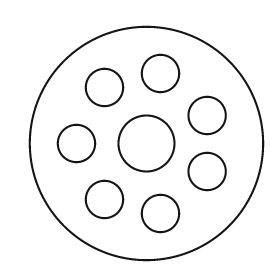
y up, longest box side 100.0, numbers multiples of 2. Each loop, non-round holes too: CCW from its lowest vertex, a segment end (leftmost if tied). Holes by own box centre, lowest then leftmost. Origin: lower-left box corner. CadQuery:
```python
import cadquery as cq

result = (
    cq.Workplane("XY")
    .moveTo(50.0, 50.0)
    .circle(50.0)
    .moveTo(56.0, 20.0)
    .circle(8.0)
    .moveTo(32.0, 26.0)
    .circle(8.0)
    .moveTo(76.0, 38.0)
    .circle(8.0)
    .moveTo(20.0, 50.0)
    .circle(8.0)
    .moveTo(50.0, 50.0)
    .circle(12.0)
    .moveTo(76.0, 62.0)
    .circle(8.0)
    .moveTo(32.0, 74.0)
    .circle(8.0)
    .moveTo(56.0, 80.0)
    .circle(8.0)
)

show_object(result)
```